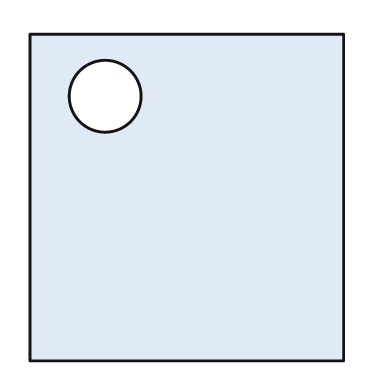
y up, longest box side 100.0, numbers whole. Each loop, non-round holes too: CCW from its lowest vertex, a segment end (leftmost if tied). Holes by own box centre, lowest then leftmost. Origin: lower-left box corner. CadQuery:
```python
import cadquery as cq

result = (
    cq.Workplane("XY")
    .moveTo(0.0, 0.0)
    .lineTo(96.0, 0.0)
    .lineTo(96.0, 100.0)
    .lineTo(0.0, 100.0)
    .close()
    .moveTo(23.0, 81.0)
    .circle(11.0)
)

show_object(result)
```